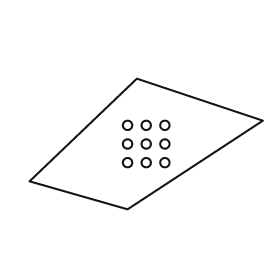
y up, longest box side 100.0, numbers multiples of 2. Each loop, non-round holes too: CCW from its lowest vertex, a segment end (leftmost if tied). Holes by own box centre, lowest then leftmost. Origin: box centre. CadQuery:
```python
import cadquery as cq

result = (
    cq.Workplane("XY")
    .moveTo(-8.0, -28.0)
    .lineTo(50.0, 10.0)
    .lineTo(-4.0, 28.0)
    .lineTo(-50.0, -16.0)
    .close()
    .moveTo(-8.0, -8.0)
    .circle(2.0)
    .moveTo(0.0, -8.0)
    .circle(2.0)
    .moveTo(8.0, -8.0)
    .circle(2.0)
    .moveTo(-8.0, 0.0)
    .circle(2.0)
    .moveTo(0.0, 0.0)
    .circle(2.0)
    .moveTo(8.0, 0.0)
    .circle(2.0)
    .moveTo(-8.0, 8.0)
    .circle(2.0)
    .moveTo(0.0, 8.0)
    .circle(2.0)
    .moveTo(8.0, 8.0)
    .circle(2.0)
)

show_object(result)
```